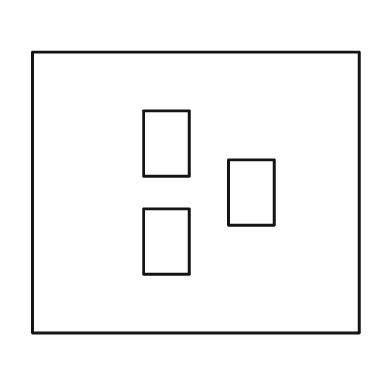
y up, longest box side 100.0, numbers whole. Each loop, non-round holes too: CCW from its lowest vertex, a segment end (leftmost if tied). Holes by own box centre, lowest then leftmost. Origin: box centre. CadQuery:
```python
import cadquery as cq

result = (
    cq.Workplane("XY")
    .moveTo(-50.0, -43.0)
    .lineTo(50.0, -43.0)
    .lineTo(50.0, 43.0)
    .lineTo(-50.0, 43.0)
    .close()
    .moveTo(-16.0, -25.0)
    .lineTo(-2.0, -25.0)
    .lineTo(-2.0, -5.0)
    .lineTo(-16.0, -5.0)
    .close()
    .moveTo(10.0, -10.0)
    .lineTo(24.0, -10.0)
    .lineTo(24.0, 10.0)
    .lineTo(10.0, 10.0)
    .close()
    .moveTo(-16.0, 5.0)
    .lineTo(-2.0, 5.0)
    .lineTo(-2.0, 25.0)
    .lineTo(-16.0, 25.0)
    .close()
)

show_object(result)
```